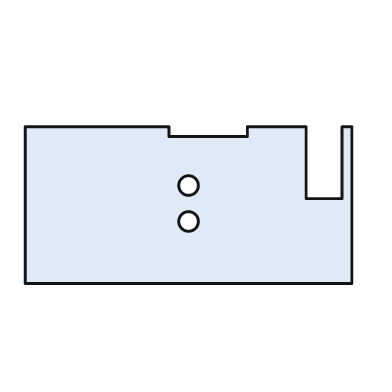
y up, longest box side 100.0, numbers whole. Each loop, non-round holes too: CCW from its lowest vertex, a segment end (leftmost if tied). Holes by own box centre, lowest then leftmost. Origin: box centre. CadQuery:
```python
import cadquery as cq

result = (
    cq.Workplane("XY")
    .moveTo(-50.0, -24.0)
    .lineTo(50.0, -24.0)
    .lineTo(50.0, 24.0)
    .lineTo(47.0, 24.0)
    .lineTo(47.0, 2.0)
    .lineTo(36.0, 2.0)
    .lineTo(36.0, 24.0)
    .lineTo(18.0, 24.0)
    .lineTo(18.0, 21.0)
    .lineTo(-6.0, 21.0)
    .lineTo(-6.0, 24.0)
    .lineTo(-50.0, 24.0)
    .close()
    .moveTo(0.0, -5.0)
    .circle(3.0)
    .moveTo(0.0, 6.0)
    .circle(3.0)
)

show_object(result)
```